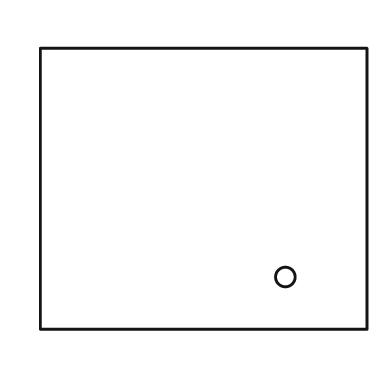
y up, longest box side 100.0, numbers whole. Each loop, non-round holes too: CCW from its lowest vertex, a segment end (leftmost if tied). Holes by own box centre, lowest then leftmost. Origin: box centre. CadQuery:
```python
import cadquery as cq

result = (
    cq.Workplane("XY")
    .moveTo(-50.0, -43.0)
    .lineTo(50.0, -43.0)
    .lineTo(50.0, 43.0)
    .lineTo(-50.0, 43.0)
    .close()
    .moveTo(25.0, -27.0)
    .circle(3.0)
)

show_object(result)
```